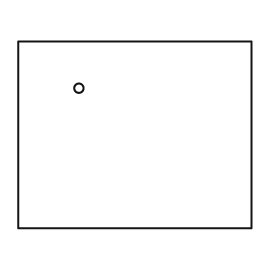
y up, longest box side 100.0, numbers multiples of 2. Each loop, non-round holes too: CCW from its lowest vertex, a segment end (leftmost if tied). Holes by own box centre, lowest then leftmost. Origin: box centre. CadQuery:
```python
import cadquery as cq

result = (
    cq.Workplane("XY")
    .moveTo(-50.0, -40.0)
    .lineTo(50.0, -40.0)
    .lineTo(50.0, 40.0)
    .lineTo(-50.0, 40.0)
    .close()
    .moveTo(-24.0, 20.0)
    .circle(2.0)
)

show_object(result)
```